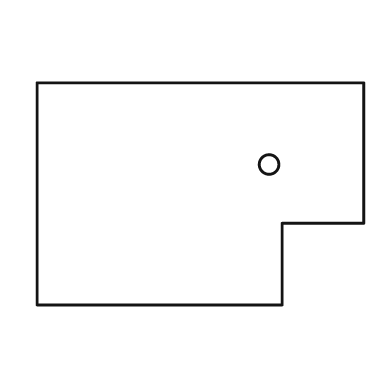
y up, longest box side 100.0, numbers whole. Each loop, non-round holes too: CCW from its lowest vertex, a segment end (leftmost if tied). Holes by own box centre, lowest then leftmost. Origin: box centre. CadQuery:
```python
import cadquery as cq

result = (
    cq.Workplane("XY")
    .moveTo(-50.0, -34.0)
    .lineTo(25.0, -34.0)
    .lineTo(25.0, -9.0)
    .lineTo(50.0, -9.0)
    .lineTo(50.0, 34.0)
    .lineTo(-50.0, 34.0)
    .close()
    .moveTo(21.0, 9.0)
    .circle(3.0)
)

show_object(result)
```